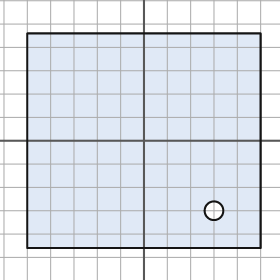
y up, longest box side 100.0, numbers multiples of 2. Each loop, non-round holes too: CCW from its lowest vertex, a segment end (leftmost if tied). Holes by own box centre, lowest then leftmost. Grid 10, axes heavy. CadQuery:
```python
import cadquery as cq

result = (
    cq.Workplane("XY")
    .moveTo(-50.0, -46.0)
    .lineTo(50.0, -46.0)
    .lineTo(50.0, 46.0)
    .lineTo(-50.0, 46.0)
    .close()
    .moveTo(30.0, -30.0)
    .circle(4.0)
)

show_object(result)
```